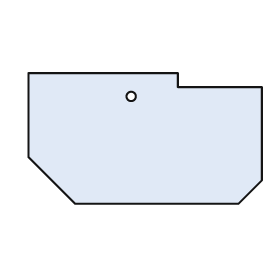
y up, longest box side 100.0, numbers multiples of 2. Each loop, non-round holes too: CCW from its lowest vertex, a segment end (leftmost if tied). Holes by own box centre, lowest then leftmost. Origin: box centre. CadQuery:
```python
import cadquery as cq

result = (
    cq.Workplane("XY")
    .moveTo(-30.0, -28.0)
    .lineTo(40.0, -28.0)
    .lineTo(50.0, -18.0)
    .lineTo(50.0, 22.0)
    .lineTo(14.0, 22.0)
    .lineTo(14.0, 28.0)
    .lineTo(-50.0, 28.0)
    .lineTo(-50.0, -8.0)
    .close()
    .moveTo(-6.0, 18.0)
    .circle(2.0)
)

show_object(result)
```